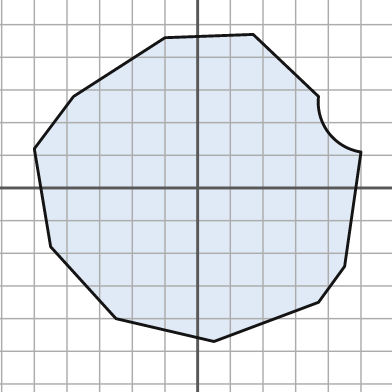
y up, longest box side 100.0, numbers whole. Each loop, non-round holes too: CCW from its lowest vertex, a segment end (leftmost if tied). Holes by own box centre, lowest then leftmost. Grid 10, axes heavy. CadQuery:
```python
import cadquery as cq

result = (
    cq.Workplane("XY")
    .moveTo(5.0, -47.0)
    .lineTo(37.0, -35.0)
    .lineTo(45.0, -24.0)
    .lineTo(50.0, 11.0)
    .threePointArc((40.0, 17.0), (37.0, 28.0))
    .lineTo(17.0, 47.0)
    .lineTo(-10.0, 46.0)
    .lineTo(-38.0, 28.0)
    .lineTo(-50.0, 12.0)
    .lineTo(-45.0, -18.0)
    .lineTo(-25.0, -40.0)
    .close()
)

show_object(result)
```